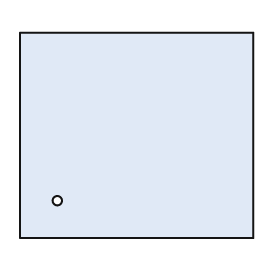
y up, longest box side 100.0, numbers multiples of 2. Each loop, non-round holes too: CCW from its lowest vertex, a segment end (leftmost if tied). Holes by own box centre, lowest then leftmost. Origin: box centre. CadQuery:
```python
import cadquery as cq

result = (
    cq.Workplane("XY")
    .moveTo(-50.0, -44.0)
    .lineTo(50.0, -44.0)
    .lineTo(50.0, 44.0)
    .lineTo(-50.0, 44.0)
    .close()
    .moveTo(-34.0, -28.0)
    .circle(2.0)
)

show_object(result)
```